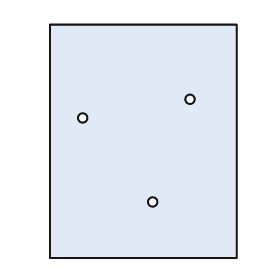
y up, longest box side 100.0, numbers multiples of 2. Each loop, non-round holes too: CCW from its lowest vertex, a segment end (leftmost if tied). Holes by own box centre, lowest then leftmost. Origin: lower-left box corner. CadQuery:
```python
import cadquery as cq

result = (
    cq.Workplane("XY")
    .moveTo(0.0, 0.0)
    .lineTo(80.0, 0.0)
    .lineTo(80.0, 100.0)
    .lineTo(0.0, 100.0)
    .close()
    .moveTo(44.0, 24.0)
    .circle(2.0)
    .moveTo(14.0, 60.0)
    .circle(2.0)
    .moveTo(60.0, 68.0)
    .circle(2.0)
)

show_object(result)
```